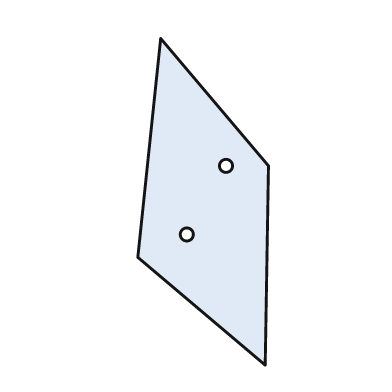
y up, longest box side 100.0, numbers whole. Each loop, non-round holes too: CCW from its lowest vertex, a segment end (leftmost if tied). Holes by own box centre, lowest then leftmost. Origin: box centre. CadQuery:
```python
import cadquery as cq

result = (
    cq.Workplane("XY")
    .moveTo(19.0, -50.0)
    .lineTo(20.0, 11.0)
    .lineTo(-13.0, 50.0)
    .lineTo(-20.0, -17.0)
    .close()
    .moveTo(-5.0, -10.0)
    .circle(2.0)
    .moveTo(7.0, 11.0)
    .circle(2.0)
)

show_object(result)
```